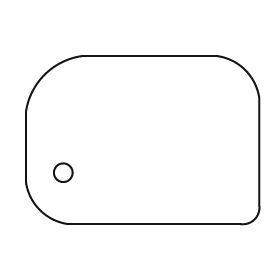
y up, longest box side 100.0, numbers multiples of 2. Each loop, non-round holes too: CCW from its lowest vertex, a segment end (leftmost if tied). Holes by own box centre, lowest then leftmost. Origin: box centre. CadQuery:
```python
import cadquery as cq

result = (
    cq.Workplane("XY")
    .moveTo(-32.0, -36.0)
    .lineTo(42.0, -36.0)
    .threePointArc((48.0, -34.0), (50.0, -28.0))
    .lineTo(50.0, 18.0)
    .threePointArc((44.0, 30.0), (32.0, 36.0))
    .lineTo(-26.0, 36.0)
    .threePointArc((-42.0, 28.0), (-50.0, 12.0))
    .lineTo(-50.0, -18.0)
    .threePointArc((-44.0, -30.0), (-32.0, -36.0))
    .close()
    .moveTo(-34.0, -14.0)
    .circle(4.0)
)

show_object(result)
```